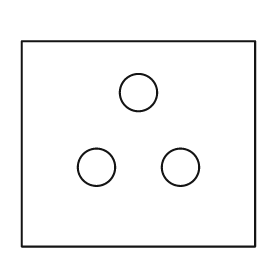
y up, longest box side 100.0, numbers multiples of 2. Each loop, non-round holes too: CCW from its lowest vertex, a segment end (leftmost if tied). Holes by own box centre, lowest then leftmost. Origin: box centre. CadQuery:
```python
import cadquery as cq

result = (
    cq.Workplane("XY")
    .moveTo(-50.0, -44.0)
    .lineTo(50.0, -44.0)
    .lineTo(50.0, 44.0)
    .lineTo(-50.0, 44.0)
    .close()
    .moveTo(-18.0, -10.0)
    .circle(8.0)
    .moveTo(18.0, -10.0)
    .circle(8.0)
    .moveTo(0.0, 22.0)
    .circle(8.0)
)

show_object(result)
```